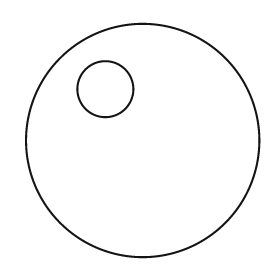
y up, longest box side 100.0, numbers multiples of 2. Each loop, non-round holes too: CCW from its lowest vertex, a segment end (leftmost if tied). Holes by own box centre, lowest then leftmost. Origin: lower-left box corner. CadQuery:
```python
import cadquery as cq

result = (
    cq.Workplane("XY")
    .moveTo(50.0, 50.0)
    .circle(50.0)
    .moveTo(34.0, 72.0)
    .circle(12.0)
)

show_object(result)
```